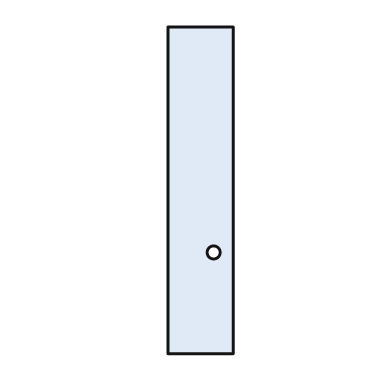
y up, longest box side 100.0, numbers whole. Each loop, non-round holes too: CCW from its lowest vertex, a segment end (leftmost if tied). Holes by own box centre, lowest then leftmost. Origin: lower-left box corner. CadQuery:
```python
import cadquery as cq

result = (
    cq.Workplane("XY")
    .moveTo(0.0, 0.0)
    .lineTo(20.0, 0.0)
    .lineTo(20.0, 100.0)
    .lineTo(0.0, 100.0)
    .close()
    .moveTo(14.0, 31.0)
    .circle(2.0)
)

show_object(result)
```